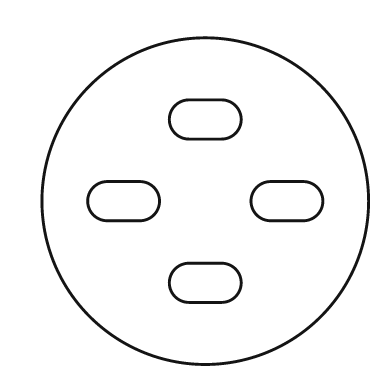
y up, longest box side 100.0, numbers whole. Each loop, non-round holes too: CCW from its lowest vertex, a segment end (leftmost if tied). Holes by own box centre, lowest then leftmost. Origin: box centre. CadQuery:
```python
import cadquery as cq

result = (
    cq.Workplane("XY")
    .moveTo(0.0, 0.0)
    .circle(50.0)
    .moveTo(-5.0, -31.0)
    .lineTo(5.0, -31.0)
    .threePointArc((11.0, -25.0), (5.0, -19.0))
    .lineTo(-5.0, -19.0)
    .threePointArc((-11.0, -25.0), (-5.0, -31.0))
    .close()
    .moveTo(-30.0, -6.0)
    .lineTo(-20.0, -6.0)
    .threePointArc((-14.0, 0.0), (-20.0, 6.0))
    .lineTo(-30.0, 6.0)
    .threePointArc((-36.0, 0.0), (-30.0, -6.0))
    .close()
    .moveTo(20.0, -6.0)
    .lineTo(30.0, -6.0)
    .threePointArc((36.0, 0.0), (30.0, 6.0))
    .lineTo(20.0, 6.0)
    .threePointArc((14.0, 0.0), (20.0, -6.0))
    .close()
    .moveTo(-5.0, 19.0)
    .lineTo(5.0, 19.0)
    .threePointArc((11.0, 25.0), (5.0, 31.0))
    .lineTo(-5.0, 31.0)
    .threePointArc((-11.0, 25.0), (-5.0, 19.0))
    .close()
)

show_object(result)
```